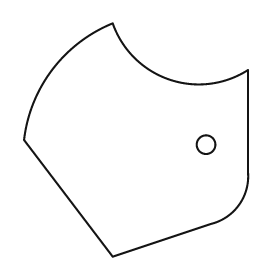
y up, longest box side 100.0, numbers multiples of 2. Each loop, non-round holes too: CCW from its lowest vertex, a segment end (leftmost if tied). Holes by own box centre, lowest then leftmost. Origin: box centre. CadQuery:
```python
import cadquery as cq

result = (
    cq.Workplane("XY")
    .moveTo(-10.0, -50.0)
    .lineTo(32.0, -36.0)
    .threePointArc((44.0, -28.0), (48.0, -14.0))
    .lineTo(48.0, 30.0)
    .threePointArc((14.0, 26.0), (-10.0, 50.0))
    .threePointArc((-36.0, 30.0), (-48.0, 0.0))
    .close()
    .moveTo(30.0, -2.0)
    .circle(4.0)
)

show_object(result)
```